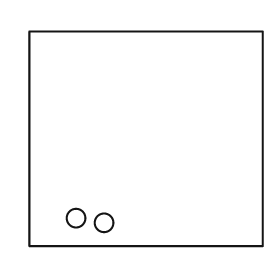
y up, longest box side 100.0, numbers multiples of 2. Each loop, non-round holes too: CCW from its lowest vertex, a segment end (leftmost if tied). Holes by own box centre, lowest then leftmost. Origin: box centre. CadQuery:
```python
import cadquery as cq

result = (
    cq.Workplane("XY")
    .moveTo(-50.0, -46.0)
    .lineTo(50.0, -46.0)
    .lineTo(50.0, 46.0)
    .lineTo(-50.0, 46.0)
    .close()
    .moveTo(-18.0, -36.0)
    .circle(4.0)
    .moveTo(-30.0, -34.0)
    .circle(4.0)
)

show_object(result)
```